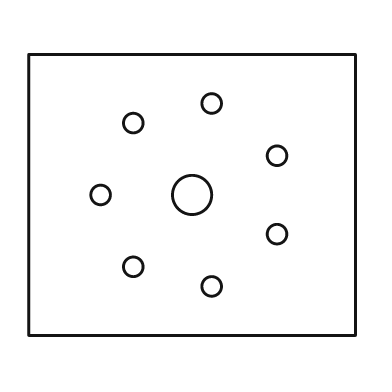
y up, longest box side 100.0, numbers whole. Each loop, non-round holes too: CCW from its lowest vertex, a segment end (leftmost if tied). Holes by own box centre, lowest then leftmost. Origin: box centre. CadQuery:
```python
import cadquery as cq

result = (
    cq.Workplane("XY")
    .moveTo(-50.0, -43.0)
    .lineTo(50.0, -43.0)
    .lineTo(50.0, 43.0)
    .lineTo(-50.0, 43.0)
    .close()
    .moveTo(6.0, -28.0)
    .circle(3.0)
    .moveTo(-18.0, -22.0)
    .circle(3.0)
    .moveTo(26.0, -12.0)
    .circle(3.0)
    .moveTo(-28.0, 0.0)
    .circle(3.0)
    .moveTo(0.0, 0.0)
    .circle(6.0)
    .moveTo(26.0, 12.0)
    .circle(3.0)
    .moveTo(-18.0, 22.0)
    .circle(3.0)
    .moveTo(6.0, 28.0)
    .circle(3.0)
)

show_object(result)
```